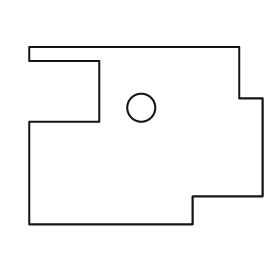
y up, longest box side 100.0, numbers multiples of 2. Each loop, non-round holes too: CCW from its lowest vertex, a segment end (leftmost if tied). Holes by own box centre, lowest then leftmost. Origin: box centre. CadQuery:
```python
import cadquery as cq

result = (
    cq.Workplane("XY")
    .moveTo(-50.0, -38.0)
    .lineTo(20.0, -38.0)
    .lineTo(20.0, -26.0)
    .lineTo(50.0, -26.0)
    .lineTo(50.0, 16.0)
    .lineTo(40.0, 16.0)
    .lineTo(40.0, 38.0)
    .lineTo(-50.0, 38.0)
    .lineTo(-50.0, 32.0)
    .lineTo(-20.0, 32.0)
    .lineTo(-20.0, 6.0)
    .lineTo(-50.0, 6.0)
    .close()
    .moveTo(-2.0, 12.0)
    .circle(6.0)
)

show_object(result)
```